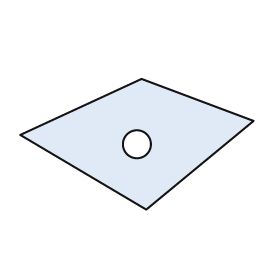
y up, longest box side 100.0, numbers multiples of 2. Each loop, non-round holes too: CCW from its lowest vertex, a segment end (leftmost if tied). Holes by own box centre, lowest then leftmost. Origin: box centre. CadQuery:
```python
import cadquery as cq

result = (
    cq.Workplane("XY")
    .moveTo(4.0, -28.0)
    .lineTo(50.0, 10.0)
    .lineTo(2.0, 28.0)
    .lineTo(-50.0, 4.0)
    .close()
    .moveTo(0.0, 0.0)
    .circle(6.0)
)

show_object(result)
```